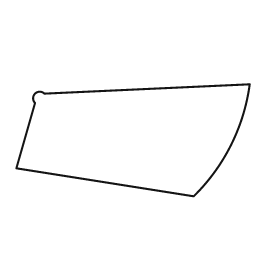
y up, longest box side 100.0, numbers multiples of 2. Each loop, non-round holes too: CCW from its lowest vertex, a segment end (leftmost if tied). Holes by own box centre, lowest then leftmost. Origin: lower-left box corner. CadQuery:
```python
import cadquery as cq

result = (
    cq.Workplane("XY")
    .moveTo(76.0, 0.0)
    .threePointArc((92.0, 22.0), (100.0, 48.0))
    .lineTo(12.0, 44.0)
    .threePointArc((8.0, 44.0), (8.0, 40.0))
    .lineTo(0.0, 12.0)
    .close()
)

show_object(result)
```